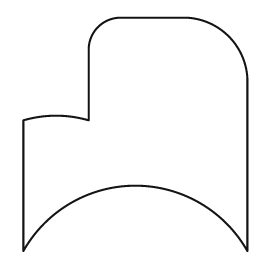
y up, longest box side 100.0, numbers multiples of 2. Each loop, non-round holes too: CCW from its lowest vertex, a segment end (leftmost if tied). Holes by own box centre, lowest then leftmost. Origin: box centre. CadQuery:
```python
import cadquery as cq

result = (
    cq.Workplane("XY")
    .moveTo(-48.0, -50.0)
    .threePointArc((0.0, -22.0), (48.0, -50.0))
    .lineTo(48.0, 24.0)
    .threePointArc((40.0, 42.0), (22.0, 50.0))
    .lineTo(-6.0, 50.0)
    .threePointArc((-16.0, 46.0), (-20.0, 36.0))
    .lineTo(-20.0, 6.0)
    .threePointArc((-34.0, 8.0), (-48.0, 6.0))
    .close()
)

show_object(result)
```